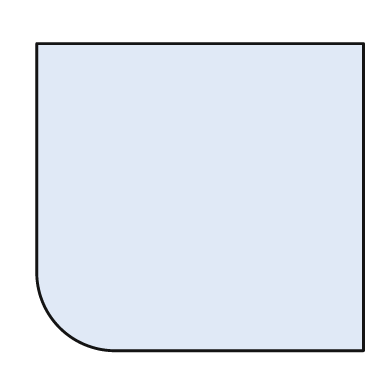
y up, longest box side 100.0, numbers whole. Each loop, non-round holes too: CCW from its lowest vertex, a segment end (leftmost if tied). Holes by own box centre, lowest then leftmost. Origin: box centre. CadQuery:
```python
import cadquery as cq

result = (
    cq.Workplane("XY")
    .moveTo(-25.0, -47.0)
    .lineTo(50.0, -47.0)
    .lineTo(50.0, 47.0)
    .lineTo(-50.0, 47.0)
    .lineTo(-50.0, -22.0)
    .threePointArc((-43.0, -40.0), (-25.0, -47.0))
    .close()
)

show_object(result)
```